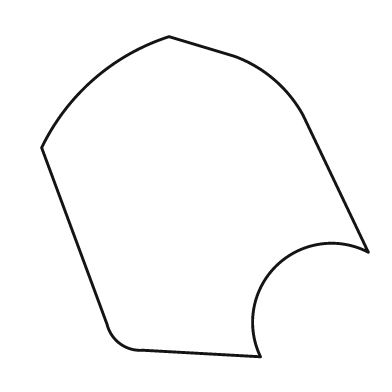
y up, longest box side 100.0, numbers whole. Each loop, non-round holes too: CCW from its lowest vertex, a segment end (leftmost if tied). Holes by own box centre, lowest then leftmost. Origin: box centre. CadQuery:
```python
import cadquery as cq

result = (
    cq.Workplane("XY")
    .moveTo(17.0, -49.0)
    .threePointArc((22.0, -21.0), (50.0, -17.0))
    .lineTo(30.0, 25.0)
    .threePointArc((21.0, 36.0), (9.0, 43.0))
    .lineTo(-11.0, 49.0)
    .threePointArc((-34.0, 36.0), (-50.0, 15.0))
    .lineTo(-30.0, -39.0)
    .threePointArc((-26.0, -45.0), (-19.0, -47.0))
    .close()
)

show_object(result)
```